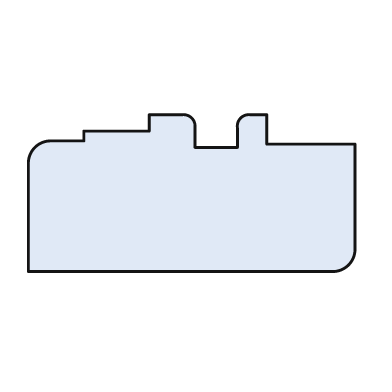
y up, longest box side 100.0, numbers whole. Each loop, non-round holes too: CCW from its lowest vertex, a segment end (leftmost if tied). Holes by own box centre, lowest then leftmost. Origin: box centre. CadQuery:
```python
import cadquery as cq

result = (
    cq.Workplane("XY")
    .moveTo(-50.0, -24.0)
    .lineTo(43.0, -24.0)
    .threePointArc((48.0, -22.0), (50.0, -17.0))
    .lineTo(50.0, 15.0)
    .lineTo(23.0, 15.0)
    .lineTo(23.0, 24.0)
    .lineTo(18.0, 24.0)
    .threePointArc((15.0, 23.0), (14.0, 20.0))
    .lineTo(14.0, 14.0)
    .lineTo(1.0, 14.0)
    .lineTo(1.0, 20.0)
    .threePointArc((0.0, 23.0), (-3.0, 24.0))
    .lineTo(-13.0, 24.0)
    .lineTo(-13.0, 19.0)
    .lineTo(-33.0, 19.0)
    .lineTo(-33.0, 16.0)
    .lineTo(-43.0, 16.0)
    .threePointArc((-48.0, 14.0), (-50.0, 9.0))
    .close()
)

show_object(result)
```